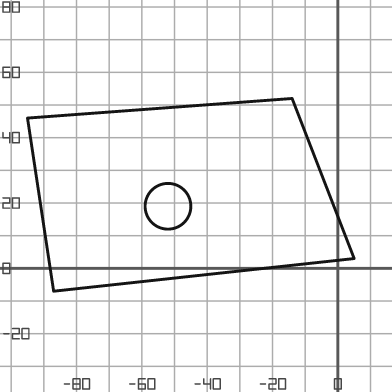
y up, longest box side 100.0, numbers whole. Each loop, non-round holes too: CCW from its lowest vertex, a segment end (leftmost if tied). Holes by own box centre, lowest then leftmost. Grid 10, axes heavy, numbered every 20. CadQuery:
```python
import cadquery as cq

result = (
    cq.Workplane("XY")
    .moveTo(-87.0, -7.0)
    .lineTo(5.0, 3.0)
    .lineTo(-14.0, 52.0)
    .lineTo(-95.0, 46.0)
    .close()
    .moveTo(-52.0, 19.0)
    .circle(7.0)
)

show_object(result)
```